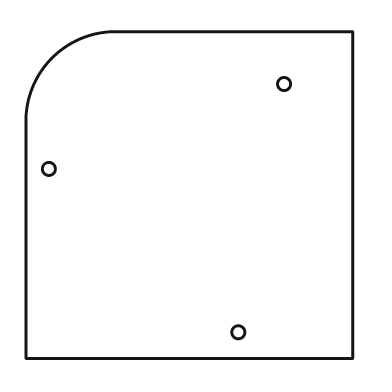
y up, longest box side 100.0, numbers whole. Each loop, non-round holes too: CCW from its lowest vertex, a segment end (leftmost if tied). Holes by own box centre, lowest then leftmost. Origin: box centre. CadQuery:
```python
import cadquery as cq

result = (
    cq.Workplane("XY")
    .moveTo(-50.0, -50.0)
    .lineTo(50.0, -50.0)
    .lineTo(50.0, 50.0)
    .lineTo(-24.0, 50.0)
    .threePointArc((-42.0, 42.0), (-50.0, 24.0))
    .close()
    .moveTo(15.0, -42.0)
    .circle(2.0)
    .moveTo(-43.0, 8.0)
    .circle(2.0)
    .moveTo(29.0, 34.0)
    .circle(2.0)
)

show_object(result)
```